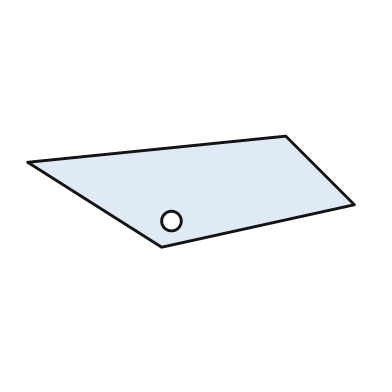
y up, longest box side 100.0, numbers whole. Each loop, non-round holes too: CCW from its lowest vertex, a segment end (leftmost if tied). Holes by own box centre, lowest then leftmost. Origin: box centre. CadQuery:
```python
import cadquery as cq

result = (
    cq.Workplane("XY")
    .moveTo(-9.0, -17.0)
    .lineTo(50.0, -4.0)
    .lineTo(29.0, 17.0)
    .lineTo(-50.0, 9.0)
    .close()
    .moveTo(-6.0, -9.0)
    .circle(3.0)
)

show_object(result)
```